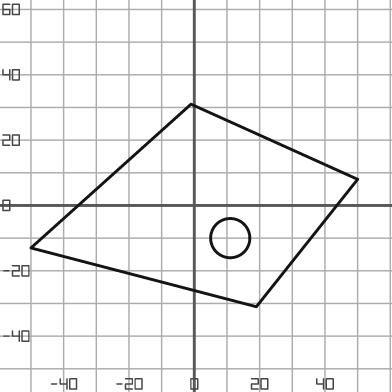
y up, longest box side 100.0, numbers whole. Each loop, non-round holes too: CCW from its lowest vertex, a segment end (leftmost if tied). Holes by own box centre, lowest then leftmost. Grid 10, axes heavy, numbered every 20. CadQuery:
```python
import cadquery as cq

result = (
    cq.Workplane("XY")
    .moveTo(19.0, -31.0)
    .lineTo(50.0, 8.0)
    .lineTo(-1.0, 31.0)
    .lineTo(-50.0, -13.0)
    .close()
    .moveTo(11.0, -10.0)
    .circle(6.0)
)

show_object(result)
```